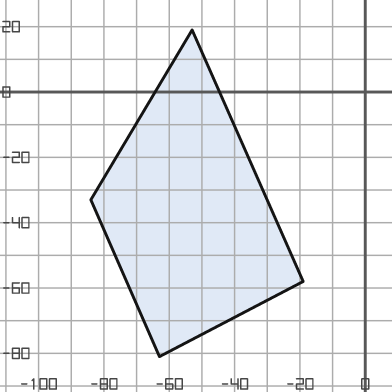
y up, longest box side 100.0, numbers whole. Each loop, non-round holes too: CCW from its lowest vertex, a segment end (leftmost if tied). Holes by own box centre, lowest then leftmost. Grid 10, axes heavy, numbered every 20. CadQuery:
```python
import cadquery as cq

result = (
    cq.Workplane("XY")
    .moveTo(-63.0, -81.0)
    .lineTo(-19.0, -58.0)
    .lineTo(-53.0, 19.0)
    .lineTo(-84.0, -33.0)
    .close()
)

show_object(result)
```